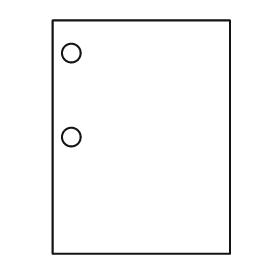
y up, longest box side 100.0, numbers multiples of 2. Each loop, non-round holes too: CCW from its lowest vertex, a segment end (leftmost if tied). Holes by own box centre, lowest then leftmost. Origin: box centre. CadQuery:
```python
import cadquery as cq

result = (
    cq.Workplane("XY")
    .moveTo(-38.0, -50.0)
    .lineTo(38.0, -50.0)
    .lineTo(38.0, 50.0)
    .lineTo(-38.0, 50.0)
    .close()
    .moveTo(-30.0, 0.0)
    .circle(4.0)
    .moveTo(-30.0, 36.0)
    .circle(4.0)
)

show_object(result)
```